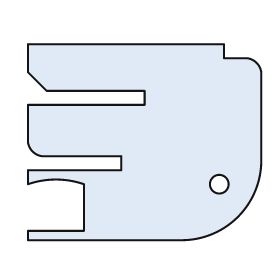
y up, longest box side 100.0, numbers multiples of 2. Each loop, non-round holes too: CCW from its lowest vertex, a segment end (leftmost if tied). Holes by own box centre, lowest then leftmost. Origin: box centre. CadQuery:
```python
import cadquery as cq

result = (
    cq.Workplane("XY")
    .moveTo(-50.0, -42.0)
    .lineTo(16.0, -42.0)
    .threePointArc((40.0, -32.0), (50.0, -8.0))
    .lineTo(50.0, 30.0)
    .threePointArc((48.0, 34.0), (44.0, 36.0))
    .lineTo(34.0, 36.0)
    .lineTo(34.0, 42.0)
    .lineTo(-50.0, 42.0)
    .lineTo(-50.0, 30.0)
    .lineTo(-42.0, 22.0)
    .lineTo(0.0, 22.0)
    .lineTo(0.0, 16.0)
    .lineTo(-50.0, 16.0)
    .lineTo(-50.0, 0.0)
    .threePointArc((-48.0, -4.0), (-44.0, -6.0))
    .lineTo(-10.0, -6.0)
    .lineTo(-10.0, -12.0)
    .lineTo(-50.0, -12.0)
    .lineTo(-50.0, -18.0)
    .threePointArc((-38.0, -16.0), (-26.0, -18.0))
    .lineTo(-26.0, -38.0)
    .lineTo(-50.0, -38.0)
    .close()
    .moveTo(32.0, -18.0)
    .circle(4.0)
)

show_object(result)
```